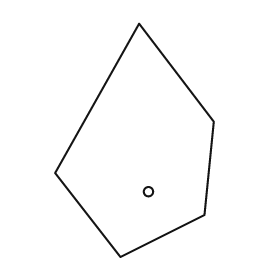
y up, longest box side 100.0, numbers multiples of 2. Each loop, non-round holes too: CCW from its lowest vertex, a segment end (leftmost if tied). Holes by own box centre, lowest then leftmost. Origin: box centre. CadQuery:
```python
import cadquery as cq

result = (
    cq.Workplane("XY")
    .moveTo(-6.0, -50.0)
    .lineTo(30.0, -32.0)
    .lineTo(34.0, 8.0)
    .lineTo(2.0, 50.0)
    .lineTo(-34.0, -14.0)
    .close()
    .moveTo(6.0, -22.0)
    .circle(2.0)
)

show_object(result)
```